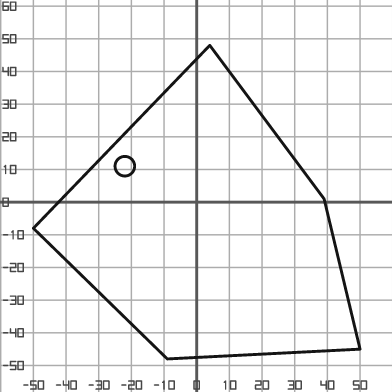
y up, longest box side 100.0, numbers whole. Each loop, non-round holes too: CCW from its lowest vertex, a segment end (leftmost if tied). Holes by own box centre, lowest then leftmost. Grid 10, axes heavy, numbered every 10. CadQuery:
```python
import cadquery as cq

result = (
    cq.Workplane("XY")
    .moveTo(-9.0, -48.0)
    .lineTo(50.0, -45.0)
    .lineTo(39.0, 1.0)
    .lineTo(4.0, 48.0)
    .lineTo(-50.0, -8.0)
    .close()
    .moveTo(-22.0, 11.0)
    .circle(3.0)
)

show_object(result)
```